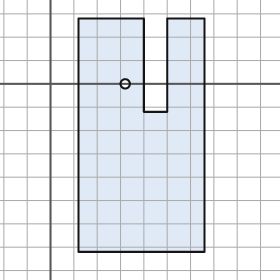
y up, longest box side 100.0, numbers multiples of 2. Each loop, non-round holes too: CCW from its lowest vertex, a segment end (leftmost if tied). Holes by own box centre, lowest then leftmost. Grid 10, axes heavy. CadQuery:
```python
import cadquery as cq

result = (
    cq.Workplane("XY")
    .moveTo(12.0, -72.0)
    .lineTo(66.0, -72.0)
    .lineTo(66.0, 28.0)
    .lineTo(50.0, 28.0)
    .lineTo(50.0, -12.0)
    .lineTo(40.0, -12.0)
    .lineTo(40.0, 28.0)
    .lineTo(12.0, 28.0)
    .close()
    .moveTo(32.0, 0.0)
    .circle(2.0)
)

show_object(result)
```